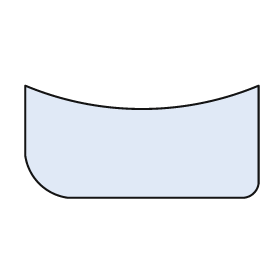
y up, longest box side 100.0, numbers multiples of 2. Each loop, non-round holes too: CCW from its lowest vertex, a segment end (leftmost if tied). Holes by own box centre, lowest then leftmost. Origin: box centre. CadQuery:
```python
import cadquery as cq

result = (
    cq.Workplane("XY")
    .moveTo(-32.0, -24.0)
    .lineTo(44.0, -24.0)
    .threePointArc((48.0, -22.0), (50.0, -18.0))
    .lineTo(50.0, 24.0)
    .threePointArc((0.0, 14.0), (-50.0, 24.0))
    .lineTo(-50.0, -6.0)
    .threePointArc((-44.0, -18.0), (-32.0, -24.0))
    .close()
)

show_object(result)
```